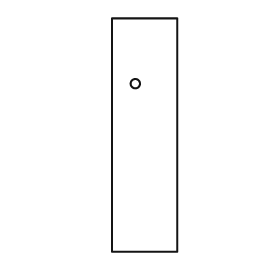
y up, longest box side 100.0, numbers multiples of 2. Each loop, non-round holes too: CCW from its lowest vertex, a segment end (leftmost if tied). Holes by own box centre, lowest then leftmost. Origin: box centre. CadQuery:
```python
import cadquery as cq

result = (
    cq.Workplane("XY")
    .moveTo(-14.0, -50.0)
    .lineTo(14.0, -50.0)
    .lineTo(14.0, 50.0)
    .lineTo(-14.0, 50.0)
    .close()
    .moveTo(-4.0, 22.0)
    .circle(2.0)
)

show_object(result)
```